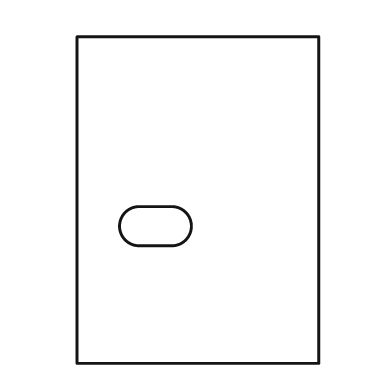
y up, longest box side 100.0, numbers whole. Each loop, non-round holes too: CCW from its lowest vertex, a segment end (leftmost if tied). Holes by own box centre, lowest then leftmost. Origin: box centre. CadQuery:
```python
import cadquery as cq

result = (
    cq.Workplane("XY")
    .moveTo(-37.0, -50.0)
    .lineTo(37.0, -50.0)
    .lineTo(37.0, 50.0)
    .lineTo(-37.0, 50.0)
    .close()
    .moveTo(-18.0, -14.0)
    .lineTo(-8.0, -14.0)
    .threePointArc((-2.0, -8.0), (-8.0, -2.0))
    .lineTo(-18.0, -2.0)
    .threePointArc((-24.0, -8.0), (-18.0, -14.0))
    .close()
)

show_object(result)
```